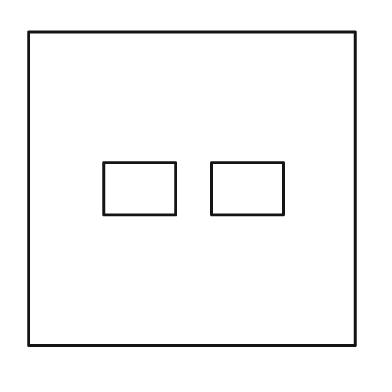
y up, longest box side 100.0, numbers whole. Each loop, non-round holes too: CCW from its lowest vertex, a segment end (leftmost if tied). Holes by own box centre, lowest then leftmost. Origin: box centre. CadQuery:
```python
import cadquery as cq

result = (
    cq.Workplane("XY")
    .moveTo(-50.0, -48.0)
    .lineTo(50.0, -48.0)
    .lineTo(50.0, 48.0)
    .lineTo(-50.0, 48.0)
    .close()
    .moveTo(-27.0, -8.0)
    .lineTo(-5.0, -8.0)
    .lineTo(-5.0, 8.0)
    .lineTo(-27.0, 8.0)
    .close()
    .moveTo(6.0, -8.0)
    .lineTo(28.0, -8.0)
    .lineTo(28.0, 8.0)
    .lineTo(6.0, 8.0)
    .close()
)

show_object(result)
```